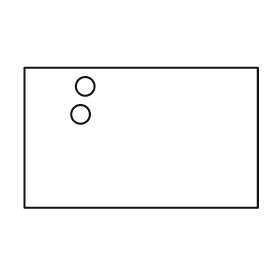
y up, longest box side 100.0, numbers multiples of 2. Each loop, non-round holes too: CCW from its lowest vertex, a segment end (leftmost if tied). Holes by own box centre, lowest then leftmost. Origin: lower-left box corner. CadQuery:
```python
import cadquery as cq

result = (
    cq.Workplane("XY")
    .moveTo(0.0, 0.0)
    .lineTo(100.0, 0.0)
    .lineTo(100.0, 60.0)
    .lineTo(0.0, 60.0)
    .close()
    .moveTo(24.0, 40.0)
    .circle(4.0)
    .moveTo(26.0, 52.0)
    .circle(4.0)
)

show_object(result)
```